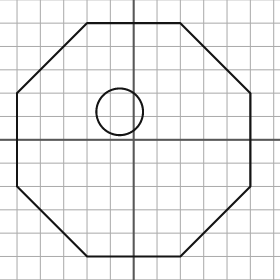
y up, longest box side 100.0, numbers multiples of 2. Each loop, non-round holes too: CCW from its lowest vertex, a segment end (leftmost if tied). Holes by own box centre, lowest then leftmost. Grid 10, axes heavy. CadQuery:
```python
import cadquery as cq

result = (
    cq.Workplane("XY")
    .moveTo(-20.0, -50.0)
    .lineTo(20.0, -50.0)
    .lineTo(50.0, -20.0)
    .lineTo(50.0, 20.0)
    .lineTo(20.0, 50.0)
    .lineTo(-20.0, 50.0)
    .lineTo(-50.0, 20.0)
    .lineTo(-50.0, -20.0)
    .close()
    .moveTo(-6.0, 12.0)
    .circle(10.0)
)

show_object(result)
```